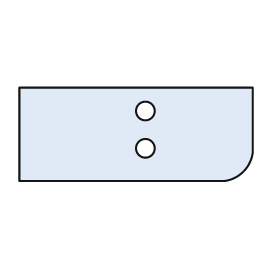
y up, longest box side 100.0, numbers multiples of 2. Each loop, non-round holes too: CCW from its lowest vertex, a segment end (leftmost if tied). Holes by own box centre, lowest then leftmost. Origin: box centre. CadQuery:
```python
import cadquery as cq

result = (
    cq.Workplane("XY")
    .moveTo(-50.0, -20.0)
    .lineTo(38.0, -20.0)
    .threePointArc((46.0, -16.0), (50.0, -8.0))
    .lineTo(50.0, 20.0)
    .lineTo(-50.0, 20.0)
    .close()
    .moveTo(4.0, -6.0)
    .circle(4.0)
    .moveTo(4.0, 10.0)
    .circle(4.0)
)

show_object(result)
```